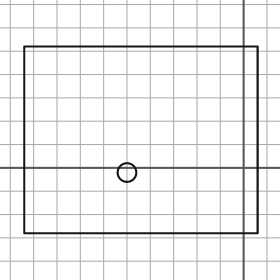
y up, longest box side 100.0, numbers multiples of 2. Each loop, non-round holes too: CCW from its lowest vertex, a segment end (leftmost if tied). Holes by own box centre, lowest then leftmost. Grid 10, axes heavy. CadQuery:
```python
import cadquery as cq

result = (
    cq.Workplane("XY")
    .moveTo(-94.0, -28.0)
    .lineTo(6.0, -28.0)
    .lineTo(6.0, 52.0)
    .lineTo(-94.0, 52.0)
    .close()
    .moveTo(-50.0, -2.0)
    .circle(4.0)
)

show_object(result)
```